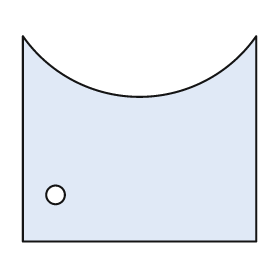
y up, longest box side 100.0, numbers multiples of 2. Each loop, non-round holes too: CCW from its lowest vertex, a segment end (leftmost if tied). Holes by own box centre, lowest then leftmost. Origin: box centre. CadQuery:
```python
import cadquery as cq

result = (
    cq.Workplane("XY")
    .moveTo(-50.0, -44.0)
    .lineTo(50.0, -44.0)
    .lineTo(50.0, 44.0)
    .threePointArc((0.0, 18.0), (-50.0, 44.0))
    .close()
    .moveTo(-36.0, -24.0)
    .circle(4.0)
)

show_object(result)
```